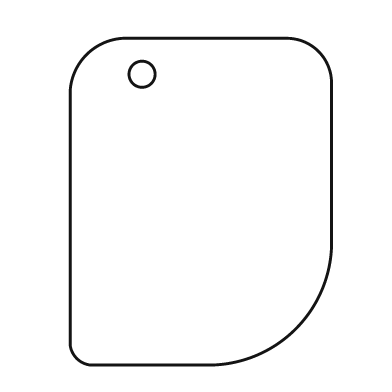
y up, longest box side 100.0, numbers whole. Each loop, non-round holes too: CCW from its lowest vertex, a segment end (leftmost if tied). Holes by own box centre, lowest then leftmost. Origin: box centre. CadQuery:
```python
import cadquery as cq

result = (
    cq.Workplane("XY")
    .moveTo(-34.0, -50.0)
    .lineTo(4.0, -50.0)
    .threePointArc((29.0, -39.0), (40.0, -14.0))
    .lineTo(40.0, 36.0)
    .threePointArc((36.0, 46.0), (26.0, 50.0))
    .lineTo(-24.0, 50.0)
    .threePointArc((-35.0, 45.0), (-40.0, 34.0))
    .lineTo(-40.0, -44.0)
    .threePointArc((-38.0, -48.0), (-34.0, -50.0))
    .close()
    .moveTo(-18.0, 39.0)
    .circle(4.0)
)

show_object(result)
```